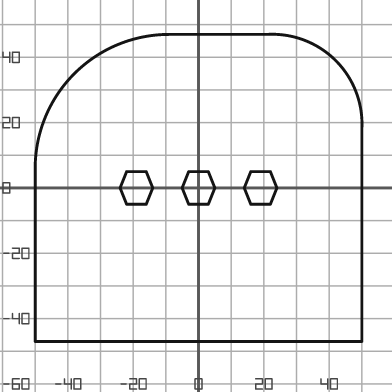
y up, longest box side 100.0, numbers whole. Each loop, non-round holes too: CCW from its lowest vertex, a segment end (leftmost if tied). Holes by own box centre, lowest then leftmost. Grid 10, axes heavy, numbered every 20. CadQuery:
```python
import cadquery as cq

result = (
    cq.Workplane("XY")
    .moveTo(-50.0, -47.0)
    .lineTo(50.0, -47.0)
    .lineTo(50.0, 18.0)
    .threePointArc((42.0, 39.0), (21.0, 47.0))
    .lineTo(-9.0, 47.0)
    .threePointArc((-38.0, 35.0), (-50.0, 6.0))
    .close()
    .moveTo(-22.0, -5.0)
    .lineTo(-16.0, -5.0)
    .lineTo(-14.0, 0.0)
    .lineTo(-16.0, 5.0)
    .lineTo(-22.0, 5.0)
    .lineTo(-24.0, 0.0)
    .close()
    .moveTo(-3.0, -5.0)
    .lineTo(3.0, -5.0)
    .lineTo(5.0, 0.0)
    .lineTo(3.0, 5.0)
    .lineTo(-3.0, 5.0)
    .lineTo(-5.0, 0.0)
    .close()
    .moveTo(16.0, -5.0)
    .lineTo(22.0, -5.0)
    .lineTo(24.0, 0.0)
    .lineTo(22.0, 5.0)
    .lineTo(16.0, 5.0)
    .lineTo(14.0, 0.0)
    .close()
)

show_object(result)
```